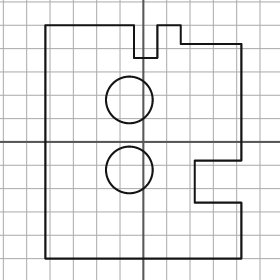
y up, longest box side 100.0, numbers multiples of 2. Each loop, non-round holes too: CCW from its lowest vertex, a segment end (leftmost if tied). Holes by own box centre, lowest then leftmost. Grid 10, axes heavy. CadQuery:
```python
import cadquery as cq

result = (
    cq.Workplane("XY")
    .moveTo(-42.0, -50.0)
    .lineTo(42.0, -50.0)
    .lineTo(42.0, -26.0)
    .lineTo(22.0, -26.0)
    .lineTo(22.0, -8.0)
    .lineTo(42.0, -8.0)
    .lineTo(42.0, 42.0)
    .lineTo(16.0, 42.0)
    .lineTo(16.0, 50.0)
    .lineTo(6.0, 50.0)
    .lineTo(6.0, 36.0)
    .lineTo(-4.0, 36.0)
    .lineTo(-4.0, 50.0)
    .lineTo(-42.0, 50.0)
    .close()
    .moveTo(-6.0, -12.0)
    .circle(10.0)
    .moveTo(-6.0, 18.0)
    .circle(10.0)
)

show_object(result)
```